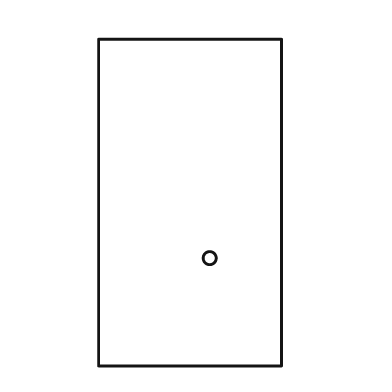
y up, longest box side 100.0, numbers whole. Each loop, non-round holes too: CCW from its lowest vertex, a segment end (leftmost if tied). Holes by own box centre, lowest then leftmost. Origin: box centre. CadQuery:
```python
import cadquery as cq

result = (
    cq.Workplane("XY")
    .moveTo(-28.0, -50.0)
    .lineTo(28.0, -50.0)
    .lineTo(28.0, 50.0)
    .lineTo(-28.0, 50.0)
    .close()
    .moveTo(6.0, -17.0)
    .circle(2.0)
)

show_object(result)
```